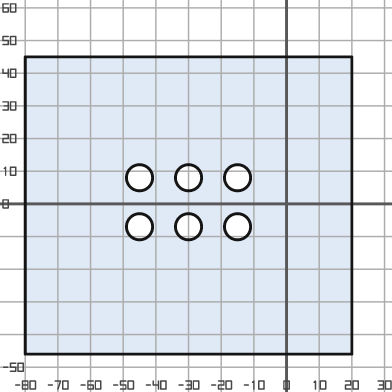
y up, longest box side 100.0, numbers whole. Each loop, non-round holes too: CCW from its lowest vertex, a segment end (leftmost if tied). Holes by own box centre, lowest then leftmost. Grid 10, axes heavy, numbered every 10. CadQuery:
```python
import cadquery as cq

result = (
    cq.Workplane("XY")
    .moveTo(-80.0, -46.0)
    .lineTo(20.0, -46.0)
    .lineTo(20.0, 45.0)
    .lineTo(-80.0, 45.0)
    .close()
    .moveTo(-45.0, -7.0)
    .circle(4.0)
    .moveTo(-30.0, -7.0)
    .circle(4.0)
    .moveTo(-15.0, -7.0)
    .circle(4.0)
    .moveTo(-45.0, 8.0)
    .circle(4.0)
    .moveTo(-30.0, 8.0)
    .circle(4.0)
    .moveTo(-15.0, 8.0)
    .circle(4.0)
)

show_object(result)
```